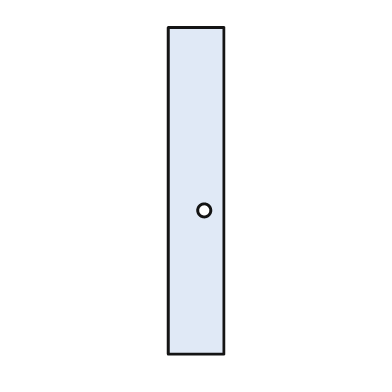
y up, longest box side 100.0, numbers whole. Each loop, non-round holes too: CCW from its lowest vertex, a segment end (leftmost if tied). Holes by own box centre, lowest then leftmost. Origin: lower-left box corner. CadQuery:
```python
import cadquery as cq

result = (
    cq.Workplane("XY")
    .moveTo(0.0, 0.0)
    .lineTo(17.0, 0.0)
    .lineTo(17.0, 100.0)
    .lineTo(0.0, 100.0)
    .close()
    .moveTo(11.0, 44.0)
    .circle(2.0)
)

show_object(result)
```